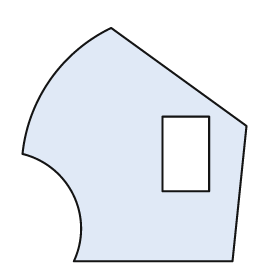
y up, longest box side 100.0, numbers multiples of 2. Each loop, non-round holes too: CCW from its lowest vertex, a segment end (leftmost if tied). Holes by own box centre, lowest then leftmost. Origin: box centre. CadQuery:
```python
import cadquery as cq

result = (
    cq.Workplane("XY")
    .moveTo(-26.0, -50.0)
    .lineTo(42.0, -50.0)
    .lineTo(48.0, 8.0)
    .lineTo(-10.0, 50.0)
    .threePointArc((-36.0, 28.0), (-48.0, -4.0))
    .threePointArc((-26.0, -22.0), (-26.0, -50.0))
    .close()
    .moveTo(12.0, -20.0)
    .lineTo(32.0, -20.0)
    .lineTo(32.0, 12.0)
    .lineTo(12.0, 12.0)
    .close()
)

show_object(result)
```